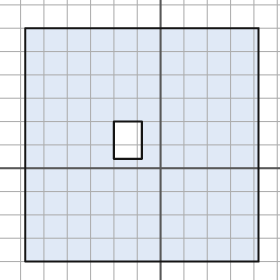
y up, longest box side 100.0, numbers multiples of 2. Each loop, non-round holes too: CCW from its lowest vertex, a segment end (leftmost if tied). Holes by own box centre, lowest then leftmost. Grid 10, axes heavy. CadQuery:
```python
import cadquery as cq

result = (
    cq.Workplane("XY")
    .moveTo(-58.0, -40.0)
    .lineTo(42.0, -40.0)
    .lineTo(42.0, 60.0)
    .lineTo(-58.0, 60.0)
    .close()
    .moveTo(-20.0, 4.0)
    .lineTo(-8.0, 4.0)
    .lineTo(-8.0, 20.0)
    .lineTo(-20.0, 20.0)
    .close()
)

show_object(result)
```